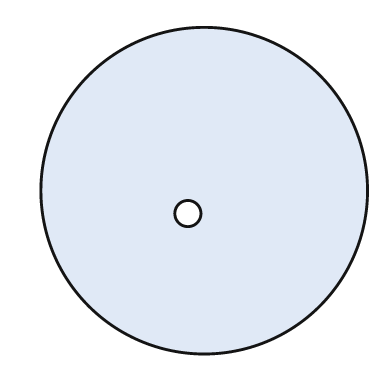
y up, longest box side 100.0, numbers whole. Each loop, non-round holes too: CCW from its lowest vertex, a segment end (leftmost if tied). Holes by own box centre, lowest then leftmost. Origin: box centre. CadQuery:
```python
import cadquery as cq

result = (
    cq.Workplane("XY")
    .moveTo(0.0, 0.0)
    .circle(50.0)
    .moveTo(-5.0, -7.0)
    .circle(4.0)
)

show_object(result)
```